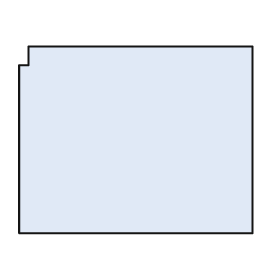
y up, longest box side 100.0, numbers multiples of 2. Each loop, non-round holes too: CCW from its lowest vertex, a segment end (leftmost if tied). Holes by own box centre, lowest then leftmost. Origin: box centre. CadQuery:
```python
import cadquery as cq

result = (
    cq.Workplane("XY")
    .moveTo(-50.0, -40.0)
    .lineTo(50.0, -40.0)
    .lineTo(50.0, 40.0)
    .lineTo(-46.0, 40.0)
    .lineTo(-46.0, 32.0)
    .lineTo(-50.0, 32.0)
    .close()
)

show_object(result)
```